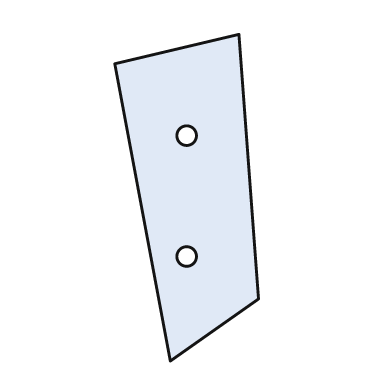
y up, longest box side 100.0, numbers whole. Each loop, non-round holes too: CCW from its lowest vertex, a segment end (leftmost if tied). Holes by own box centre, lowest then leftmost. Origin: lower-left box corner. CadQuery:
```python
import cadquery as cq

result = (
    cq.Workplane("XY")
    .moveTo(17.0, 0.0)
    .lineTo(44.0, 19.0)
    .lineTo(38.0, 100.0)
    .lineTo(0.0, 91.0)
    .close()
    .moveTo(22.0, 32.0)
    .circle(3.0)
    .moveTo(22.0, 69.0)
    .circle(3.0)
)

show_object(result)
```